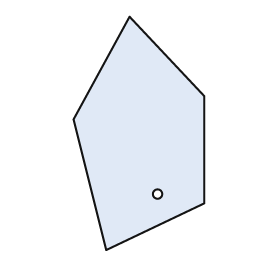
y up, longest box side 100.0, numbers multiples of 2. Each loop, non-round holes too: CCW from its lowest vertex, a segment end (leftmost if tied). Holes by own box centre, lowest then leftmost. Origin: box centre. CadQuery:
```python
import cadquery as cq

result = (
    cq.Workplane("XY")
    .moveTo(-14.0, -50.0)
    .lineTo(28.0, -30.0)
    .lineTo(28.0, 16.0)
    .lineTo(-4.0, 50.0)
    .lineTo(-28.0, 6.0)
    .close()
    .moveTo(8.0, -26.0)
    .circle(2.0)
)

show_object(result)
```